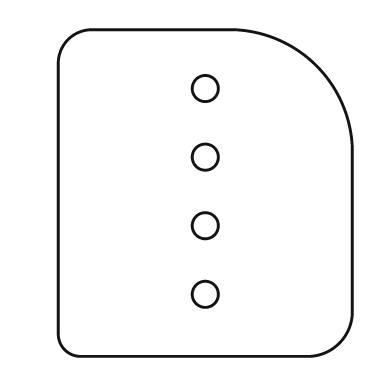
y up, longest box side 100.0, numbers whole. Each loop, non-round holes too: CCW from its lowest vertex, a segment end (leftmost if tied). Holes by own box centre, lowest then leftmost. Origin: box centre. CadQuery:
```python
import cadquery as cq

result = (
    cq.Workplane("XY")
    .moveTo(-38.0, -50.0)
    .lineTo(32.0, -50.0)
    .threePointArc((41.0, -46.0), (45.0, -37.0))
    .lineTo(45.0, 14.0)
    .threePointArc((34.0, 39.0), (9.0, 50.0))
    .lineTo(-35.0, 50.0)
    .threePointArc((-42.0, 47.0), (-45.0, 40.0))
    .lineTo(-45.0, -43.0)
    .threePointArc((-43.0, -48.0), (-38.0, -50.0))
    .close()
    .moveTo(0.0, -31.0)
    .circle(4.0)
    .moveTo(0.0, -10.0)
    .circle(4.0)
    .moveTo(0.0, 11.0)
    .circle(4.0)
    .moveTo(0.0, 32.0)
    .circle(4.0)
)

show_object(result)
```